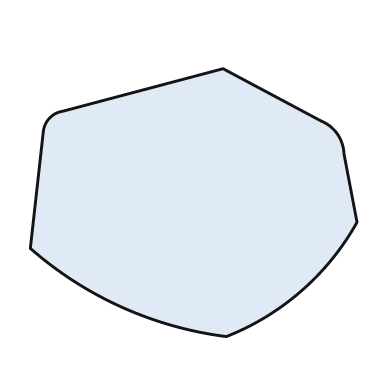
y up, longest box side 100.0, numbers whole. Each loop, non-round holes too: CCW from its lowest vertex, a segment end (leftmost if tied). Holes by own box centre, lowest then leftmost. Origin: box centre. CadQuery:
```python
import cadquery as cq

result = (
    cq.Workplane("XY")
    .moveTo(10.0, -41.0)
    .threePointArc((33.0, -27.0), (50.0, -6.0))
    .lineTo(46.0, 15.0)
    .threePointArc((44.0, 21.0), (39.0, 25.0))
    .lineTo(9.0, 41.0)
    .lineTo(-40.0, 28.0)
    .threePointArc((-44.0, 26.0), (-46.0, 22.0))
    .lineTo(-50.0, -14.0)
    .threePointArc((-22.0, -32.0), (10.0, -41.0))
    .close()
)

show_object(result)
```